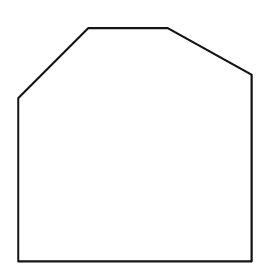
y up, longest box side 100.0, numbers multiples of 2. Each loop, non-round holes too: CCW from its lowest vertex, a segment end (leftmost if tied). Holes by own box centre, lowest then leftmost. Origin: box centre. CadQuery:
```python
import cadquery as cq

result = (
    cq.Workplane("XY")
    .moveTo(-50.0, -50.0)
    .lineTo(50.0, -50.0)
    .lineTo(50.0, 30.0)
    .lineTo(14.0, 50.0)
    .lineTo(-20.0, 50.0)
    .lineTo(-50.0, 20.0)
    .close()
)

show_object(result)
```